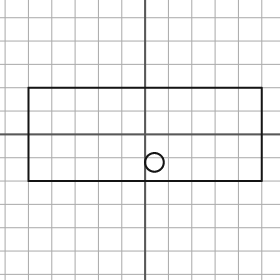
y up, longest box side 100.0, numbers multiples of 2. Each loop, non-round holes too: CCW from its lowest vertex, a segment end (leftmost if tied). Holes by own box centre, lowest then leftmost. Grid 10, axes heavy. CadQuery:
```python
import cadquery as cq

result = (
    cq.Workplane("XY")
    .moveTo(-50.0, -20.0)
    .lineTo(50.0, -20.0)
    .lineTo(50.0, 20.0)
    .lineTo(-50.0, 20.0)
    .close()
    .moveTo(4.0, -12.0)
    .circle(4.0)
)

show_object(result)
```